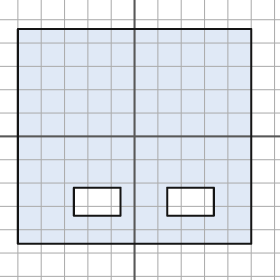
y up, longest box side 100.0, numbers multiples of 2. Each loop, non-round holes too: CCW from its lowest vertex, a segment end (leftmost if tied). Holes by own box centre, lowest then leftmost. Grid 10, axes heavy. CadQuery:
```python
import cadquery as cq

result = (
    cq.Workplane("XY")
    .moveTo(-50.0, -46.0)
    .lineTo(50.0, -46.0)
    .lineTo(50.0, 46.0)
    .lineTo(-50.0, 46.0)
    .close()
    .moveTo(-26.0, -34.0)
    .lineTo(-6.0, -34.0)
    .lineTo(-6.0, -22.0)
    .lineTo(-26.0, -22.0)
    .close()
    .moveTo(14.0, -34.0)
    .lineTo(34.0, -34.0)
    .lineTo(34.0, -22.0)
    .lineTo(14.0, -22.0)
    .close()
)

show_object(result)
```